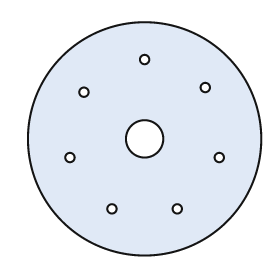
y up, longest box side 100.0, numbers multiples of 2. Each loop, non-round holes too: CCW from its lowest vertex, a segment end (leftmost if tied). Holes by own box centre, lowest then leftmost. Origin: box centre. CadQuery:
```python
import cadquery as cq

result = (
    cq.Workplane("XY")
    .moveTo(0.0, 0.0)
    .circle(50.0)
    .moveTo(-14.0, -30.0)
    .circle(2.0)
    .moveTo(14.0, -30.0)
    .circle(2.0)
    .moveTo(-32.0, -8.0)
    .circle(2.0)
    .moveTo(32.0, -8.0)
    .circle(2.0)
    .moveTo(0.0, 0.0)
    .circle(8.0)
    .moveTo(-26.0, 20.0)
    .circle(2.0)
    .moveTo(26.0, 22.0)
    .circle(2.0)
    .moveTo(0.0, 34.0)
    .circle(2.0)
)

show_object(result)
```